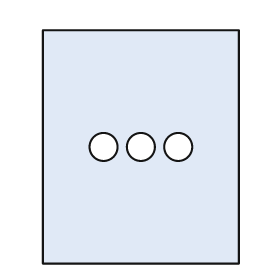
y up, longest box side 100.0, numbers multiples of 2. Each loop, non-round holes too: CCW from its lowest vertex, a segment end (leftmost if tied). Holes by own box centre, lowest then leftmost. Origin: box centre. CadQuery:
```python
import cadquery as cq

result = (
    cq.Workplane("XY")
    .moveTo(-42.0, -50.0)
    .lineTo(42.0, -50.0)
    .lineTo(42.0, 50.0)
    .lineTo(-42.0, 50.0)
    .close()
    .moveTo(-16.0, 0.0)
    .circle(6.0)
    .moveTo(0.0, 0.0)
    .circle(6.0)
    .moveTo(16.0, 0.0)
    .circle(6.0)
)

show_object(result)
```